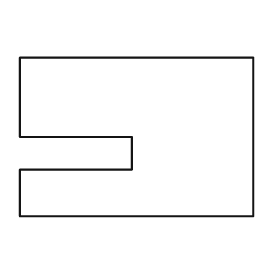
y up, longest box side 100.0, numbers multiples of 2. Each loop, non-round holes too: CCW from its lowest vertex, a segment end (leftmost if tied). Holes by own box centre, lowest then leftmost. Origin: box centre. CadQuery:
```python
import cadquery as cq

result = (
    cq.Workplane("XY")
    .moveTo(-50.0, -34.0)
    .lineTo(50.0, -34.0)
    .lineTo(50.0, 34.0)
    .lineTo(-50.0, 34.0)
    .lineTo(-50.0, 0.0)
    .lineTo(-2.0, 0.0)
    .lineTo(-2.0, -14.0)
    .lineTo(-50.0, -14.0)
    .close()
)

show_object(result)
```